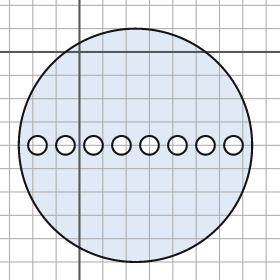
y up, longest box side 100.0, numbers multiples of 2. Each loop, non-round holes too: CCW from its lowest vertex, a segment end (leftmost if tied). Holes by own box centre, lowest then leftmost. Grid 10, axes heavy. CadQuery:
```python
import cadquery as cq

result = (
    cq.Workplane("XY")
    .moveTo(24.0, -40.0)
    .circle(50.0)
    .moveTo(-18.0, -40.0)
    .circle(4.0)
    .moveTo(-6.0, -40.0)
    .circle(4.0)
    .moveTo(6.0, -40.0)
    .circle(4.0)
    .moveTo(18.0, -40.0)
    .circle(4.0)
    .moveTo(30.0, -40.0)
    .circle(4.0)
    .moveTo(42.0, -40.0)
    .circle(4.0)
    .moveTo(54.0, -40.0)
    .circle(4.0)
    .moveTo(66.0, -40.0)
    .circle(4.0)
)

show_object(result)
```